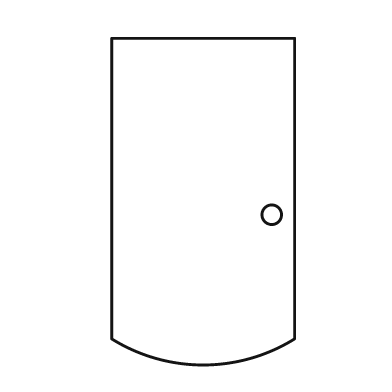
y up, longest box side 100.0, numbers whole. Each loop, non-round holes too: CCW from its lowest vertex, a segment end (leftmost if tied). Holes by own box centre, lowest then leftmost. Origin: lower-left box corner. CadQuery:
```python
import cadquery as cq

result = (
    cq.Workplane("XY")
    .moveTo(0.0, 8.0)
    .threePointArc((28.0, 0.0), (56.0, 8.0))
    .lineTo(56.0, 100.0)
    .lineTo(0.0, 100.0)
    .close()
    .moveTo(49.0, 46.0)
    .circle(3.0)
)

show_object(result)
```